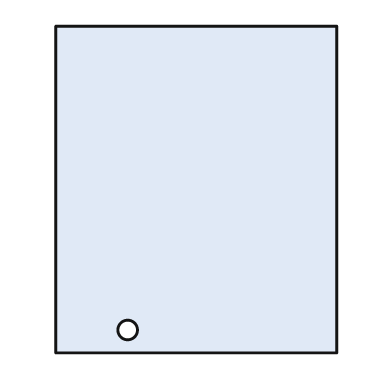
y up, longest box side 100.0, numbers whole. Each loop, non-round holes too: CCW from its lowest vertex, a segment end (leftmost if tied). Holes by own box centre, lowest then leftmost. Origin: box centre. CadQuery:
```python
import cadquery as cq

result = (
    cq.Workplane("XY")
    .moveTo(-43.0, -50.0)
    .lineTo(43.0, -50.0)
    .lineTo(43.0, 50.0)
    .lineTo(-43.0, 50.0)
    .close()
    .moveTo(-21.0, -43.0)
    .circle(3.0)
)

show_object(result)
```